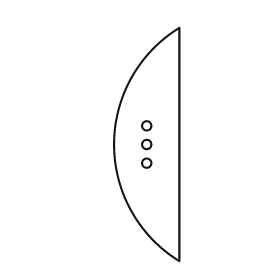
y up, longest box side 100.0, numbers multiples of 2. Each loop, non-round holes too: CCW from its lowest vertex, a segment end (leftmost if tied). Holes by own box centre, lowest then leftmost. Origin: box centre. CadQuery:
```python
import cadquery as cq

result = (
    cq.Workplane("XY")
    .moveTo(14.0, -50.0)
    .lineTo(14.0, 50.0)
    .threePointArc((-14.0, 0.0), (14.0, -50.0))
    .close()
    .moveTo(0.0, -8.0)
    .circle(2.0)
    .moveTo(0.0, 0.0)
    .circle(2.0)
    .moveTo(0.0, 8.0)
    .circle(2.0)
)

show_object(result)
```